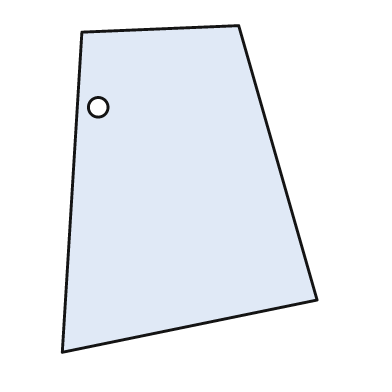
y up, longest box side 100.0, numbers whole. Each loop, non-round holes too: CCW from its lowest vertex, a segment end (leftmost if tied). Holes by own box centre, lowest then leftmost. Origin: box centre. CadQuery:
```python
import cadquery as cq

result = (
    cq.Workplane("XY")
    .moveTo(-39.0, -50.0)
    .lineTo(39.0, -34.0)
    .lineTo(15.0, 50.0)
    .lineTo(-33.0, 48.0)
    .close()
    .moveTo(-28.0, 25.0)
    .circle(3.0)
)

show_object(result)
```